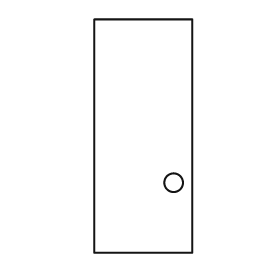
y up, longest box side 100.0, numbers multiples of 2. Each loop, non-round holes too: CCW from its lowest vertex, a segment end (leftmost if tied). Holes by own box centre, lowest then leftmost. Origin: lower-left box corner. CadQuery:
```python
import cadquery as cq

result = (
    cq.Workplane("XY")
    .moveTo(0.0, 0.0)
    .lineTo(42.0, 0.0)
    .lineTo(42.0, 100.0)
    .lineTo(0.0, 100.0)
    .close()
    .moveTo(34.0, 30.0)
    .circle(4.0)
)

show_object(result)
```